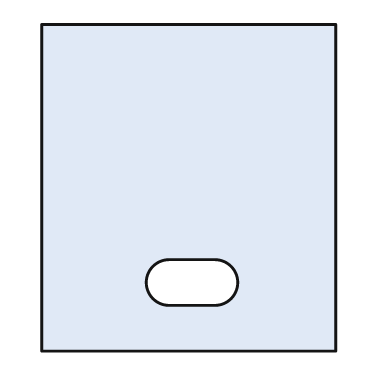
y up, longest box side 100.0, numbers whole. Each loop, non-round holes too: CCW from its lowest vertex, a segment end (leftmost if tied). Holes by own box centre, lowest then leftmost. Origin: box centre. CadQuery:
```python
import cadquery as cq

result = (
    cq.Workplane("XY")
    .moveTo(-45.0, -50.0)
    .lineTo(45.0, -50.0)
    .lineTo(45.0, 50.0)
    .lineTo(-45.0, 50.0)
    .close()
    .moveTo(-6.0, -36.0)
    .lineTo(8.0, -36.0)
    .threePointArc((15.0, -29.0), (8.0, -22.0))
    .lineTo(-6.0, -22.0)
    .threePointArc((-13.0, -29.0), (-6.0, -36.0))
    .close()
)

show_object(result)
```